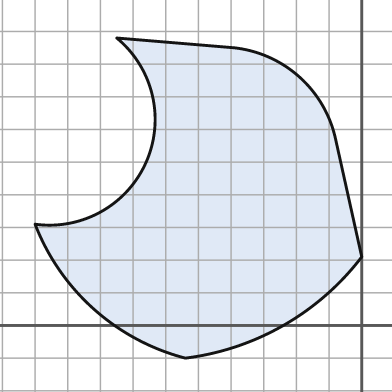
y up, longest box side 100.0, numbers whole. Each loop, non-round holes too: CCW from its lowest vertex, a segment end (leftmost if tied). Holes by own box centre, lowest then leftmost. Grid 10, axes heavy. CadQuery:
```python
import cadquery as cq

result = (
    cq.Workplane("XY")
    .moveTo(-54.0, -10.0)
    .threePointArc((-24.0, 0.0), (0.0, 21.0))
    .lineTo(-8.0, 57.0)
    .threePointArc((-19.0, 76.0), (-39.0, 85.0))
    .lineTo(-75.0, 88.0)
    .threePointArc((-66.0, 50.0), (-100.0, 31.0))
    .threePointArc((-82.0, 5.0), (-54.0, -10.0))
    .close()
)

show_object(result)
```